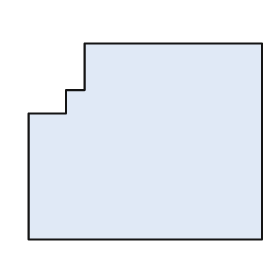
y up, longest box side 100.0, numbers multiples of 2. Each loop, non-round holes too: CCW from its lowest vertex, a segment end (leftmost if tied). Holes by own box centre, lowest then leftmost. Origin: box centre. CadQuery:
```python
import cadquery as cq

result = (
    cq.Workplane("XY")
    .moveTo(-50.0, -42.0)
    .lineTo(50.0, -42.0)
    .lineTo(50.0, 42.0)
    .lineTo(-26.0, 42.0)
    .lineTo(-26.0, 22.0)
    .lineTo(-34.0, 22.0)
    .lineTo(-34.0, 12.0)
    .lineTo(-50.0, 12.0)
    .close()
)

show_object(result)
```